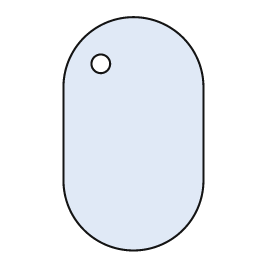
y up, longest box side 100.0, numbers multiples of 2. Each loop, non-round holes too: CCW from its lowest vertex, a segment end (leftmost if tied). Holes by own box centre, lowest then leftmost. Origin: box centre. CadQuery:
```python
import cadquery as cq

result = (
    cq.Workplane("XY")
    .moveTo(-30.0, -20.0)
    .threePointArc((0.0, -50.0), (30.0, -20.0))
    .lineTo(30.0, 20.0)
    .threePointArc((0.0, 50.0), (-30.0, 20.0))
    .close()
    .moveTo(-14.0, 30.0)
    .circle(4.0)
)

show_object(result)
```